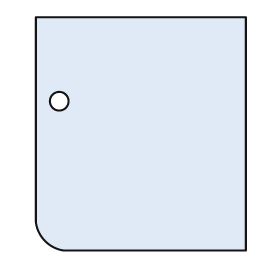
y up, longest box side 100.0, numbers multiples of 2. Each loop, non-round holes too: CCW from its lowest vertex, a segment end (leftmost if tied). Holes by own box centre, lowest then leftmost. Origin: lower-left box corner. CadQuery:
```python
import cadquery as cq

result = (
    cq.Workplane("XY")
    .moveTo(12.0, 0.0)
    .lineTo(90.0, 0.0)
    .lineTo(90.0, 100.0)
    .lineTo(0.0, 100.0)
    .lineTo(0.0, 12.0)
    .threePointArc((4.0, 4.0), (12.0, 0.0))
    .close()
    .moveTo(10.0, 64.0)
    .circle(4.0)
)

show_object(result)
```